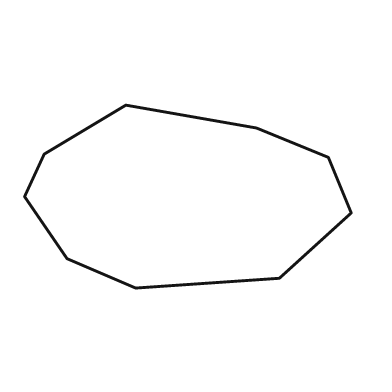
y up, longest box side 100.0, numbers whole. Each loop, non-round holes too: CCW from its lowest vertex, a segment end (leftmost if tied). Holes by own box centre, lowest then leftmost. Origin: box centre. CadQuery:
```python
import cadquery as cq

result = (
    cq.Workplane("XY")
    .moveTo(-16.0, -28.0)
    .lineTo(28.0, -25.0)
    .lineTo(50.0, -5.0)
    .lineTo(43.0, 12.0)
    .lineTo(21.0, 21.0)
    .lineTo(-19.0, 28.0)
    .lineTo(-44.0, 13.0)
    .lineTo(-50.0, 0.0)
    .lineTo(-37.0, -19.0)
    .close()
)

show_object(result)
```